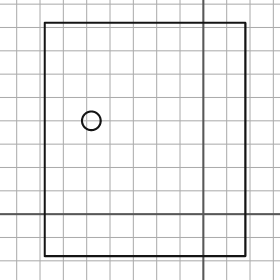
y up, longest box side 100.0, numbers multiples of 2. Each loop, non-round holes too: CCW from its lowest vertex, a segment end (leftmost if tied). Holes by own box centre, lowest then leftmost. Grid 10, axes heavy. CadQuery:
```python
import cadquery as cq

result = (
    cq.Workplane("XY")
    .moveTo(-68.0, -18.0)
    .lineTo(18.0, -18.0)
    .lineTo(18.0, 82.0)
    .lineTo(-68.0, 82.0)
    .close()
    .moveTo(-48.0, 40.0)
    .circle(4.0)
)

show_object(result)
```